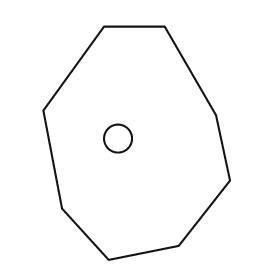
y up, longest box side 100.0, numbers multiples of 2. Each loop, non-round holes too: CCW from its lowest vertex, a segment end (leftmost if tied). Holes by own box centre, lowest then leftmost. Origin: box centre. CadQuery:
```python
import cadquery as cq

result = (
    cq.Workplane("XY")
    .moveTo(-12.0, -50.0)
    .lineTo(18.0, -44.0)
    .lineTo(40.0, -16.0)
    .lineTo(34.0, 12.0)
    .lineTo(12.0, 50.0)
    .lineTo(-14.0, 50.0)
    .lineTo(-40.0, 14.0)
    .lineTo(-32.0, -28.0)
    .close()
    .moveTo(-8.0, 2.0)
    .circle(6.0)
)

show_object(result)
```